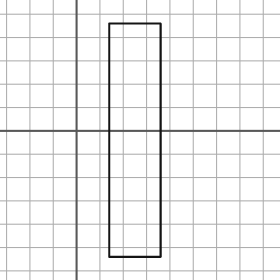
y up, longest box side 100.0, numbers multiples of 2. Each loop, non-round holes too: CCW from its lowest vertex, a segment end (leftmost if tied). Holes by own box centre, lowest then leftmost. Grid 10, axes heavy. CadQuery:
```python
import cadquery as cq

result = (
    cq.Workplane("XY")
    .moveTo(14.0, -54.0)
    .lineTo(36.0, -54.0)
    .lineTo(36.0, 46.0)
    .lineTo(14.0, 46.0)
    .close()
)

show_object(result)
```